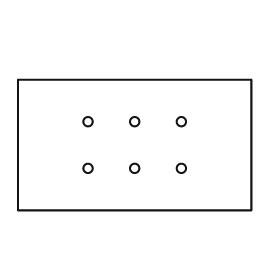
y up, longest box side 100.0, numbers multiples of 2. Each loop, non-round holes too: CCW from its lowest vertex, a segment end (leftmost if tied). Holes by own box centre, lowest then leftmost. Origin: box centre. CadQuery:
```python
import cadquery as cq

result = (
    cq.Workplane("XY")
    .moveTo(-50.0, -28.0)
    .lineTo(50.0, -28.0)
    .lineTo(50.0, 28.0)
    .lineTo(-50.0, 28.0)
    .close()
    .moveTo(-20.0, -10.0)
    .circle(2.0)
    .moveTo(0.0, -10.0)
    .circle(2.0)
    .moveTo(20.0, -10.0)
    .circle(2.0)
    .moveTo(-20.0, 10.0)
    .circle(2.0)
    .moveTo(0.0, 10.0)
    .circle(2.0)
    .moveTo(20.0, 10.0)
    .circle(2.0)
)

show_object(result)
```